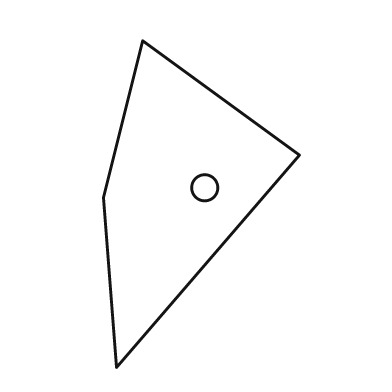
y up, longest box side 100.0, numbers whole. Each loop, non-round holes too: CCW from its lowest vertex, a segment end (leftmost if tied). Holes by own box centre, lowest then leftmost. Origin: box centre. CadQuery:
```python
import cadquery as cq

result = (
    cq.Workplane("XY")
    .moveTo(-26.0, -50.0)
    .lineTo(30.0, 15.0)
    .lineTo(-18.0, 50.0)
    .lineTo(-30.0, 2.0)
    .close()
    .moveTo(1.0, 5.0)
    .circle(4.0)
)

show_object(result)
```